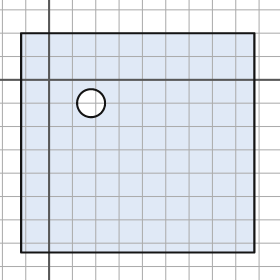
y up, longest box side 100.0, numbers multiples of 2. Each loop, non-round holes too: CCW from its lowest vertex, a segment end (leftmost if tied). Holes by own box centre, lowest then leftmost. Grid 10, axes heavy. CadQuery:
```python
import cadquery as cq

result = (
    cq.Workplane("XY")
    .moveTo(-12.0, -74.0)
    .lineTo(88.0, -74.0)
    .lineTo(88.0, 20.0)
    .lineTo(-12.0, 20.0)
    .close()
    .moveTo(18.0, -10.0)
    .circle(6.0)
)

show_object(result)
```